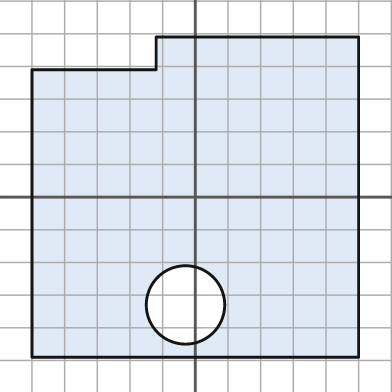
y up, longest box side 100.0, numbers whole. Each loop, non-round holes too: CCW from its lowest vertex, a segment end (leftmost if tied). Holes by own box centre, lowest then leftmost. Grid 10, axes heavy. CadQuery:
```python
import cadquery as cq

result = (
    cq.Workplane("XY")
    .moveTo(-50.0, -49.0)
    .lineTo(50.0, -49.0)
    .lineTo(50.0, 49.0)
    .lineTo(-12.0, 49.0)
    .lineTo(-12.0, 39.0)
    .lineTo(-50.0, 39.0)
    .close()
    .moveTo(-3.0, -33.0)
    .circle(12.0)
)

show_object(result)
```